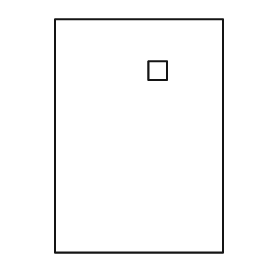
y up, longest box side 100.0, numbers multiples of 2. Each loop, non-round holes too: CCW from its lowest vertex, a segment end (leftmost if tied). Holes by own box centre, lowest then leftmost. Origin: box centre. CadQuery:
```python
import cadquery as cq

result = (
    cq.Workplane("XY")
    .moveTo(-36.0, -50.0)
    .lineTo(36.0, -50.0)
    .lineTo(36.0, 50.0)
    .lineTo(-36.0, 50.0)
    .close()
    .moveTo(4.0, 24.0)
    .lineTo(12.0, 24.0)
    .lineTo(12.0, 32.0)
    .lineTo(4.0, 32.0)
    .close()
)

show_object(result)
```